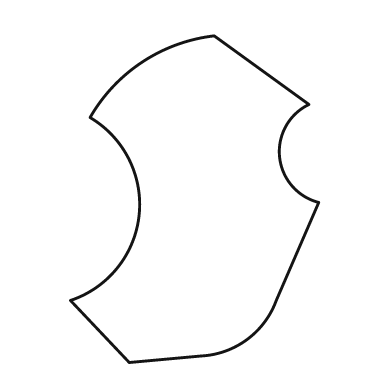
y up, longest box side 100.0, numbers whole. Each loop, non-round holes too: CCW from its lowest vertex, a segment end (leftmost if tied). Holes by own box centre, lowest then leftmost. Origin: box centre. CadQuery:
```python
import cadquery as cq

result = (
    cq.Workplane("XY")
    .moveTo(-20.0, -50.0)
    .lineTo(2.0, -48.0)
    .threePointArc((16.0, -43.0), (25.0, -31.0))
    .lineTo(38.0, -1.0)
    .threePointArc((26.0, 13.0), (35.0, 29.0))
    .lineTo(6.0, 50.0)
    .threePointArc((-16.0, 42.0), (-32.0, 25.0))
    .threePointArc((-17.0, -5.0), (-38.0, -31.0))
    .close()
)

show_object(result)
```